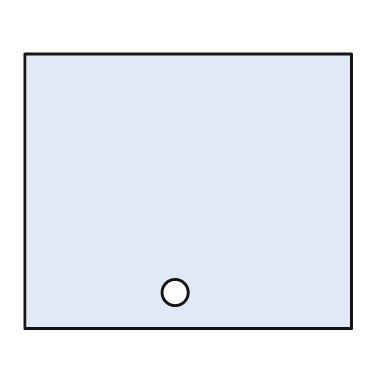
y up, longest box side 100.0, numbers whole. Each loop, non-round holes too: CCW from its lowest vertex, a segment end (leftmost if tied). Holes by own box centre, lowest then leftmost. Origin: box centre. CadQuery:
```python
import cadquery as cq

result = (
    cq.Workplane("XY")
    .moveTo(-50.0, -42.0)
    .lineTo(50.0, -42.0)
    .lineTo(50.0, 42.0)
    .lineTo(-50.0, 42.0)
    .close()
    .moveTo(-4.0, -31.0)
    .circle(4.0)
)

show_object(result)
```